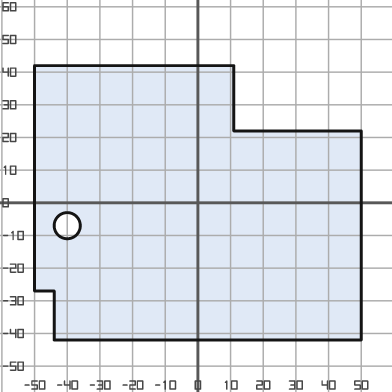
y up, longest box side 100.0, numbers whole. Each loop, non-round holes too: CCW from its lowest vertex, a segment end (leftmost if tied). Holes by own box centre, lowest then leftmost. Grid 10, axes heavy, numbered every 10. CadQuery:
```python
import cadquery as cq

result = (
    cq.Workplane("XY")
    .moveTo(-44.0, -42.0)
    .lineTo(50.0, -42.0)
    .lineTo(50.0, 22.0)
    .lineTo(11.0, 22.0)
    .lineTo(11.0, 42.0)
    .lineTo(-50.0, 42.0)
    .lineTo(-50.0, -27.0)
    .lineTo(-44.0, -27.0)
    .close()
    .moveTo(-40.0, -7.0)
    .circle(4.0)
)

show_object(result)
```